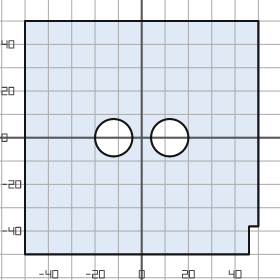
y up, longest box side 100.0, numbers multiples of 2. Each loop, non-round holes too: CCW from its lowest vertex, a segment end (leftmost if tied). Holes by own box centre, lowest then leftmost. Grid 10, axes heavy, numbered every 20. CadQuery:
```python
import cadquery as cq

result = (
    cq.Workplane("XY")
    .moveTo(-50.0, -50.0)
    .lineTo(46.0, -50.0)
    .lineTo(46.0, -38.0)
    .lineTo(50.0, -38.0)
    .lineTo(50.0, 50.0)
    .lineTo(-50.0, 50.0)
    .close()
    .moveTo(-12.0, 0.0)
    .circle(8.0)
    .moveTo(12.0, 0.0)
    .circle(8.0)
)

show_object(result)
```